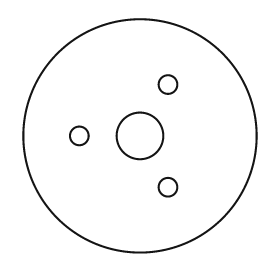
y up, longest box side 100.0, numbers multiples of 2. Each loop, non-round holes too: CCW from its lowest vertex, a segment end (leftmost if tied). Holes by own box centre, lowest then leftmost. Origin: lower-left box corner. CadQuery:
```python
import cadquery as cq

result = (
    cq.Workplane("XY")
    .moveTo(50.0, 50.0)
    .circle(50.0)
    .moveTo(62.0, 28.0)
    .circle(4.0)
    .moveTo(24.0, 50.0)
    .circle(4.0)
    .moveTo(50.0, 50.0)
    .circle(10.0)
    .moveTo(62.0, 72.0)
    .circle(4.0)
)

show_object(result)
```